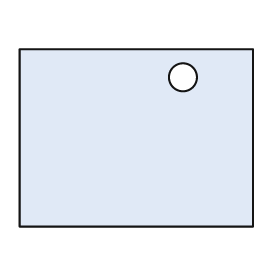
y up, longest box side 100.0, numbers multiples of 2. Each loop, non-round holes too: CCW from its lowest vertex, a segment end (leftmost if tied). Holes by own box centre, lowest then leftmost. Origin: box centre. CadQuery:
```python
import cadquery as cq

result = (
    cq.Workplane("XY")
    .moveTo(-50.0, -38.0)
    .lineTo(50.0, -38.0)
    .lineTo(50.0, 38.0)
    .lineTo(-50.0, 38.0)
    .close()
    .moveTo(20.0, 26.0)
    .circle(6.0)
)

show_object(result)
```